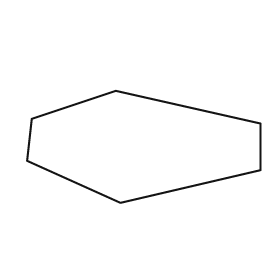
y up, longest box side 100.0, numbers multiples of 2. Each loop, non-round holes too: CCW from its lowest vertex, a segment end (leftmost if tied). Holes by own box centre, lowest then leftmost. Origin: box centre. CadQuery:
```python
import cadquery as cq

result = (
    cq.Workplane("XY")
    .moveTo(-10.0, -24.0)
    .lineTo(50.0, -10.0)
    .lineTo(50.0, 10.0)
    .lineTo(-12.0, 24.0)
    .lineTo(-48.0, 12.0)
    .lineTo(-50.0, -6.0)
    .close()
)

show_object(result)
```